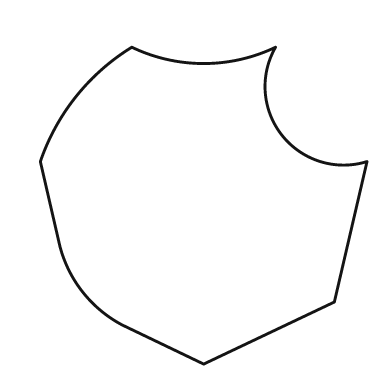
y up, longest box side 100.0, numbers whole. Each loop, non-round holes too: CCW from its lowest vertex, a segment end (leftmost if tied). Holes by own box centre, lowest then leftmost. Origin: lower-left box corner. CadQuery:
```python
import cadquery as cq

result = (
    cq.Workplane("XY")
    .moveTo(50.0, 0.0)
    .lineTo(90.0, 19.0)
    .lineTo(100.0, 62.0)
    .threePointArc((74.0, 70.0), (72.0, 97.0))
    .threePointArc((50.0, 92.0), (28.0, 97.0))
    .threePointArc((11.0, 82.0), (0.0, 62.0))
    .lineTo(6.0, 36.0)
    .threePointArc((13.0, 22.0), (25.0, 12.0))
    .close()
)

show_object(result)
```